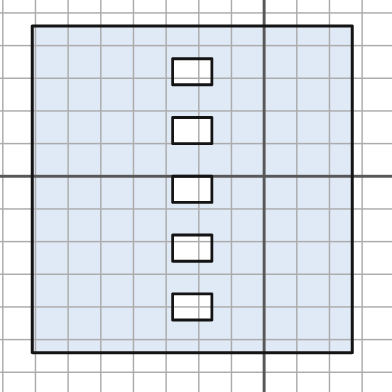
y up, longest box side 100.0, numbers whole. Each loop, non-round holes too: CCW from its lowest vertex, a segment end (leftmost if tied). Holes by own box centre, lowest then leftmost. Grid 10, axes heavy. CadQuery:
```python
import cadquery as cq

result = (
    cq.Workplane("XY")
    .moveTo(-71.0, -54.0)
    .lineTo(27.0, -54.0)
    .lineTo(27.0, 46.0)
    .lineTo(-71.0, 46.0)
    .close()
    .moveTo(-28.0, -44.0)
    .lineTo(-16.0, -44.0)
    .lineTo(-16.0, -36.0)
    .lineTo(-28.0, -36.0)
    .close()
    .moveTo(-28.0, -26.0)
    .lineTo(-16.0, -26.0)
    .lineTo(-16.0, -18.0)
    .lineTo(-28.0, -18.0)
    .close()
    .moveTo(-28.0, -8.0)
    .lineTo(-16.0, -8.0)
    .lineTo(-16.0, 0.0)
    .lineTo(-28.0, 0.0)
    .close()
    .moveTo(-28.0, 10.0)
    .lineTo(-16.0, 10.0)
    .lineTo(-16.0, 18.0)
    .lineTo(-28.0, 18.0)
    .close()
    .moveTo(-28.0, 28.0)
    .lineTo(-16.0, 28.0)
    .lineTo(-16.0, 36.0)
    .lineTo(-28.0, 36.0)
    .close()
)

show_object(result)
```